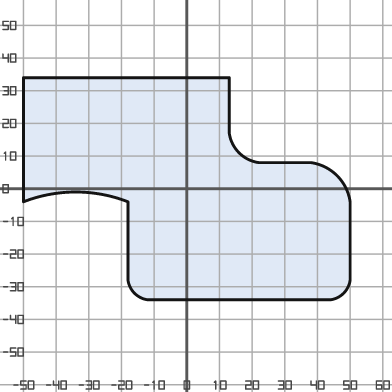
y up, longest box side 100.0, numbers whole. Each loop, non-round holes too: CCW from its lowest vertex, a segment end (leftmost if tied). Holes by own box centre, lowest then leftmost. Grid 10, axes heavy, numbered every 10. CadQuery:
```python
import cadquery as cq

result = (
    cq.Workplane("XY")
    .moveTo(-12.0, -34.0)
    .lineTo(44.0, -34.0)
    .threePointArc((48.0, -32.0), (50.0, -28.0))
    .lineTo(50.0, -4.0)
    .threePointArc((46.0, 4.0), (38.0, 8.0))
    .lineTo(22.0, 8.0)
    .threePointArc((16.0, 11.0), (13.0, 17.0))
    .lineTo(13.0, 34.0)
    .lineTo(-50.0, 34.0)
    .lineTo(-50.0, -4.0)
    .threePointArc((-34.0, -1.0), (-18.0, -4.0))
    .lineTo(-18.0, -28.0)
    .threePointArc((-16.0, -32.0), (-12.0, -34.0))
    .close()
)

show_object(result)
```